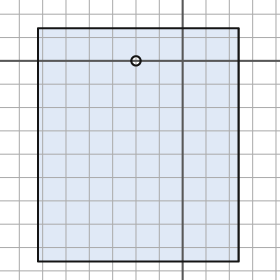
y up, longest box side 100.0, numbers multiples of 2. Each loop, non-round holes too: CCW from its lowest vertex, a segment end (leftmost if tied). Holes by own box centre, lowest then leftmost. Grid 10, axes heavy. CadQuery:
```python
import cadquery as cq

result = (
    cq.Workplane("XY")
    .moveTo(-62.0, -86.0)
    .lineTo(24.0, -86.0)
    .lineTo(24.0, 14.0)
    .lineTo(-62.0, 14.0)
    .close()
    .moveTo(-20.0, 0.0)
    .circle(2.0)
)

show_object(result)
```